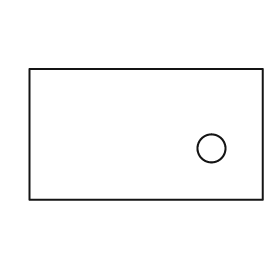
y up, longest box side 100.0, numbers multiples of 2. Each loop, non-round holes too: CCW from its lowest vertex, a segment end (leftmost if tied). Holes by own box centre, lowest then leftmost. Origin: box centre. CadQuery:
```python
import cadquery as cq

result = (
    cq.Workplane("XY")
    .moveTo(-50.0, -28.0)
    .lineTo(50.0, -28.0)
    .lineTo(50.0, 28.0)
    .lineTo(-50.0, 28.0)
    .close()
    .moveTo(28.0, -6.0)
    .circle(6.0)
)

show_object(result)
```